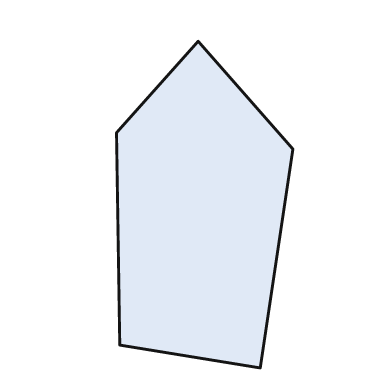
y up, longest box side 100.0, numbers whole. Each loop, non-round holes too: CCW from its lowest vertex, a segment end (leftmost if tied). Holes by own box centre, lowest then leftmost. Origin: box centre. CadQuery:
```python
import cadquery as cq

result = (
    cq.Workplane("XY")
    .moveTo(17.0, -50.0)
    .lineTo(27.0, 17.0)
    .lineTo(-2.0, 50.0)
    .lineTo(-27.0, 22.0)
    .lineTo(-26.0, -43.0)
    .close()
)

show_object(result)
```